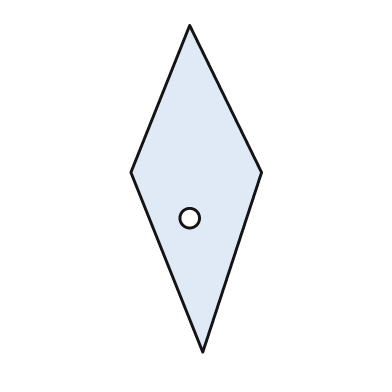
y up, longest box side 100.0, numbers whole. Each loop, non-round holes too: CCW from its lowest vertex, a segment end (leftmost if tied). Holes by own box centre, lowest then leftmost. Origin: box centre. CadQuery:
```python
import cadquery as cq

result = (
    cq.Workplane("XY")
    .moveTo(2.0, -50.0)
    .lineTo(20.0, 5.0)
    .lineTo(-2.0, 50.0)
    .lineTo(-20.0, 5.0)
    .close()
    .moveTo(-2.0, -9.0)
    .circle(3.0)
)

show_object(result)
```